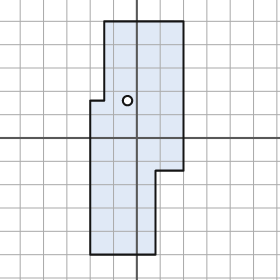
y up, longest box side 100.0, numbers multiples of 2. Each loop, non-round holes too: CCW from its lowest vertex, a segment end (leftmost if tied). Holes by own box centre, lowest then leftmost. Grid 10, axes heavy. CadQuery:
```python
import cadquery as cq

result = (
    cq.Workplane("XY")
    .moveTo(-20.0, -50.0)
    .lineTo(8.0, -50.0)
    .lineTo(8.0, -14.0)
    .lineTo(20.0, -14.0)
    .lineTo(20.0, 50.0)
    .lineTo(-14.0, 50.0)
    .lineTo(-14.0, 16.0)
    .lineTo(-20.0, 16.0)
    .close()
    .moveTo(-4.0, 16.0)
    .circle(2.0)
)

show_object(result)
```